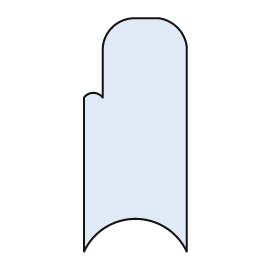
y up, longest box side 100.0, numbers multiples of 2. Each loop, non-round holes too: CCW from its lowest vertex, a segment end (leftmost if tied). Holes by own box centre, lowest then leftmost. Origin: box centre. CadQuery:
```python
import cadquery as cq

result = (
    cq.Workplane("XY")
    .moveTo(-22.0, -50.0)
    .threePointArc((0.0, -36.0), (22.0, -50.0))
    .lineTo(22.0, 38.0)
    .threePointArc((18.0, 46.0), (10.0, 50.0))
    .lineTo(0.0, 50.0)
    .threePointArc((-10.0, 46.0), (-14.0, 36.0))
    .lineTo(-14.0, 16.0)
    .threePointArc((-18.0, 18.0), (-22.0, 16.0))
    .close()
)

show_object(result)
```